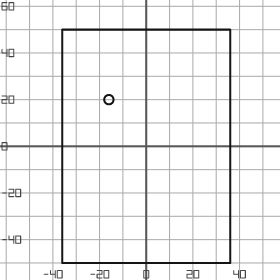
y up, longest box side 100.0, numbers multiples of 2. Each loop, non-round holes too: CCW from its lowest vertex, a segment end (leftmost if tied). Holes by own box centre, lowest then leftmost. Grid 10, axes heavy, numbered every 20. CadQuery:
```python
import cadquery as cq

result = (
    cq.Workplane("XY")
    .moveTo(-36.0, -50.0)
    .lineTo(36.0, -50.0)
    .lineTo(36.0, 50.0)
    .lineTo(-36.0, 50.0)
    .close()
    .moveTo(-16.0, 20.0)
    .circle(2.0)
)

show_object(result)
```